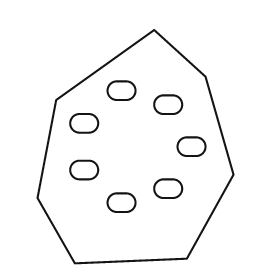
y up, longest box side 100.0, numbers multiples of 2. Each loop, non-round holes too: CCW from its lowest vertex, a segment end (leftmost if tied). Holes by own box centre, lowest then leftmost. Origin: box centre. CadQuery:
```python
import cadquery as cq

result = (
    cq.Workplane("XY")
    .moveTo(-26.0, -50.0)
    .lineTo(22.0, -48.0)
    .lineTo(42.0, -12.0)
    .lineTo(30.0, 30.0)
    .lineTo(8.0, 50.0)
    .lineTo(-34.0, 20.0)
    .lineTo(-42.0, -22.0)
    .close()
    .moveTo(-8.0, -28.0)
    .lineTo(-4.0, -28.0)
    .threePointArc((0.0, -24.0), (-4.0, -20.0))
    .lineTo(-8.0, -20.0)
    .threePointArc((-12.0, -24.0), (-8.0, -28.0))
    .close()
    .moveTo(12.0, -22.0)
    .lineTo(16.0, -22.0)
    .threePointArc((20.0, -18.0), (16.0, -14.0))
    .lineTo(12.0, -14.0)
    .threePointArc((8.0, -18.0), (12.0, -22.0))
    .close()
    .moveTo(-24.0, -14.0)
    .lineTo(-20.0, -14.0)
    .threePointArc((-16.0, -10.0), (-20.0, -6.0))
    .lineTo(-24.0, -6.0)
    .threePointArc((-28.0, -10.0), (-24.0, -14.0))
    .close()
    .moveTo(22.0, -4.0)
    .lineTo(26.0, -4.0)
    .threePointArc((30.0, 0.0), (26.0, 4.0))
    .lineTo(22.0, 4.0)
    .threePointArc((18.0, 0.0), (22.0, -4.0))
    .close()
    .moveTo(-24.0, 6.0)
    .lineTo(-20.0, 6.0)
    .threePointArc((-16.0, 10.0), (-20.0, 14.0))
    .lineTo(-24.0, 14.0)
    .threePointArc((-28.0, 10.0), (-24.0, 6.0))
    .close()
    .moveTo(12.0, 14.0)
    .lineTo(16.0, 14.0)
    .threePointArc((20.0, 18.0), (16.0, 22.0))
    .lineTo(12.0, 22.0)
    .threePointArc((8.0, 18.0), (12.0, 14.0))
    .close()
    .moveTo(-8.0, 20.0)
    .lineTo(-4.0, 20.0)
    .threePointArc((0.0, 24.0), (-4.0, 28.0))
    .lineTo(-8.0, 28.0)
    .threePointArc((-12.0, 24.0), (-8.0, 20.0))
    .close()
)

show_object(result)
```